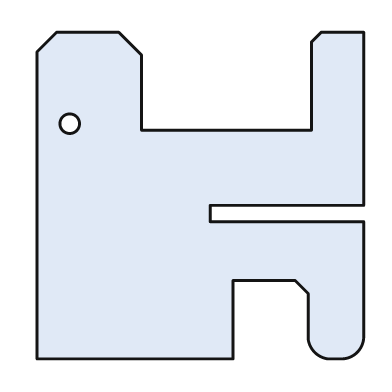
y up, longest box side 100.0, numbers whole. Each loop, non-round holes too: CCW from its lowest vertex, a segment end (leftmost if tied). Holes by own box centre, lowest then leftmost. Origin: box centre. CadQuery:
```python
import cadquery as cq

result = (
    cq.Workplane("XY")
    .moveTo(-50.0, -50.0)
    .lineTo(10.0, -50.0)
    .lineTo(10.0, -26.0)
    .lineTo(29.0, -26.0)
    .lineTo(33.0, -30.0)
    .lineTo(33.0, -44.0)
    .threePointArc((35.0, -48.0), (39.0, -50.0))
    .lineTo(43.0, -50.0)
    .threePointArc((48.0, -48.0), (50.0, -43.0))
    .lineTo(50.0, -8.0)
    .lineTo(3.0, -8.0)
    .lineTo(3.0, -3.0)
    .lineTo(50.0, -3.0)
    .lineTo(50.0, 50.0)
    .lineTo(37.0, 50.0)
    .lineTo(34.0, 47.0)
    .lineTo(34.0, 20.0)
    .lineTo(-18.0, 20.0)
    .lineTo(-18.0, 43.0)
    .lineTo(-25.0, 50.0)
    .lineTo(-44.0, 50.0)
    .lineTo(-50.0, 44.0)
    .close()
    .moveTo(-40.0, 22.0)
    .circle(3.0)
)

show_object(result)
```